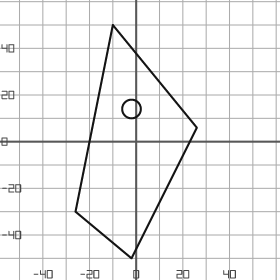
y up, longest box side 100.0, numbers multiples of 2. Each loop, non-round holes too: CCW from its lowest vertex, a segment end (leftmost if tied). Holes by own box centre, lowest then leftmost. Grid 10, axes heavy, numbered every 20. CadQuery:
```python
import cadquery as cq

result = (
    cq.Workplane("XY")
    .moveTo(-2.0, -50.0)
    .lineTo(26.0, 6.0)
    .lineTo(-10.0, 50.0)
    .lineTo(-26.0, -30.0)
    .close()
    .moveTo(-2.0, 14.0)
    .circle(4.0)
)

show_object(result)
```